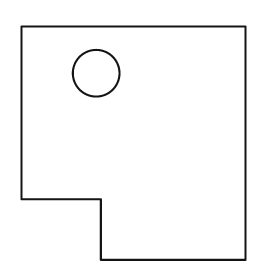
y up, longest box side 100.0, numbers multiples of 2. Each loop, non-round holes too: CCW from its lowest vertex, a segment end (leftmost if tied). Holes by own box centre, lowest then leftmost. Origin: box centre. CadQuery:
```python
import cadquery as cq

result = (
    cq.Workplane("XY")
    .moveTo(-14.0, -50.0)
    .lineTo(48.0, -50.0)
    .lineTo(48.0, 50.0)
    .lineTo(-48.0, 50.0)
    .lineTo(-48.0, -24.0)
    .lineTo(-14.0, -24.0)
    .close()
    .moveTo(-16.0, 30.0)
    .circle(10.0)
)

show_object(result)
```